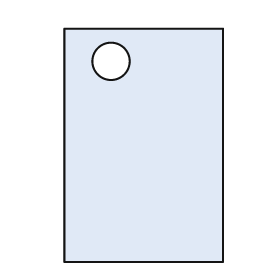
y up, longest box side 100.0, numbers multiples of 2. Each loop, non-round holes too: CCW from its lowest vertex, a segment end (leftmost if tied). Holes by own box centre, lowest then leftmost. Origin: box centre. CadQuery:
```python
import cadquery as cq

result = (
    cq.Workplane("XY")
    .moveTo(-34.0, -50.0)
    .lineTo(34.0, -50.0)
    .lineTo(34.0, 50.0)
    .lineTo(-34.0, 50.0)
    .close()
    .moveTo(-14.0, 36.0)
    .circle(8.0)
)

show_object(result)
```